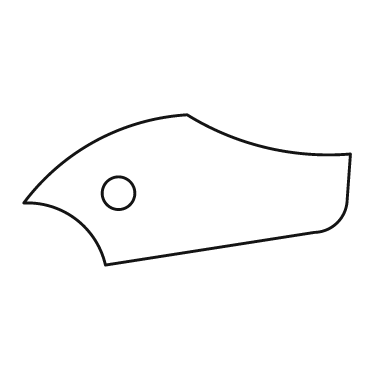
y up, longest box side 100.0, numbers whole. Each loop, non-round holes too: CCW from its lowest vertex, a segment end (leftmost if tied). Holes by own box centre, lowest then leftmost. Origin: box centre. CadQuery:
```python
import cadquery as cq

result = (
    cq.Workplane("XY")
    .moveTo(-25.0, -23.0)
    .lineTo(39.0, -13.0)
    .threePointArc((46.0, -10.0), (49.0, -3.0))
    .lineTo(50.0, 11.0)
    .threePointArc((24.0, 13.0), (0.0, 23.0))
    .threePointArc((-28.0, 15.0), (-50.0, -4.0))
    .threePointArc((-34.0, -9.0), (-25.0, -23.0))
    .close()
    .moveTo(-21.0, -1.0)
    .circle(5.0)
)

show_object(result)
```